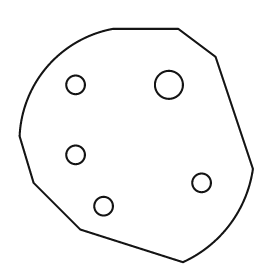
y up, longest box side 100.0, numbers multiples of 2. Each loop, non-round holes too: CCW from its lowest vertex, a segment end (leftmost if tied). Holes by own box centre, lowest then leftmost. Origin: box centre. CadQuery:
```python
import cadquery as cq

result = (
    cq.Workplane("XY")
    .moveTo(20.0, -50.0)
    .threePointArc((40.0, -34.0), (50.0, -10.0))
    .lineTo(34.0, 38.0)
    .lineTo(18.0, 50.0)
    .lineTo(-10.0, 50.0)
    .threePointArc((-38.0, 34.0), (-50.0, 4.0))
    .lineTo(-44.0, -16.0)
    .lineTo(-24.0, -36.0)
    .close()
    .moveTo(-14.0, -26.0)
    .circle(4.0)
    .moveTo(28.0, -16.0)
    .circle(4.0)
    .moveTo(-26.0, -4.0)
    .circle(4.0)
    .moveTo(-26.0, 26.0)
    .circle(4.0)
    .moveTo(14.0, 26.0)
    .circle(6.0)
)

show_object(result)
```